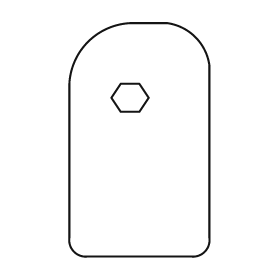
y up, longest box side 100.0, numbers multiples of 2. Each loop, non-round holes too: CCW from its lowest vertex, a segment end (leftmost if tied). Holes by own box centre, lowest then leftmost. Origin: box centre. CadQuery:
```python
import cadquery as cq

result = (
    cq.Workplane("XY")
    .moveTo(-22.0, -50.0)
    .lineTo(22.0, -50.0)
    .threePointArc((28.0, -48.0), (30.0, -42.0))
    .lineTo(30.0, 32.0)
    .threePointArc((24.0, 44.0), (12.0, 50.0))
    .lineTo(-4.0, 50.0)
    .threePointArc((-22.0, 42.0), (-30.0, 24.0))
    .lineTo(-30.0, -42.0)
    .threePointArc((-28.0, -48.0), (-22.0, -50.0))
    .close()
    .moveTo(-8.0, 12.0)
    .lineTo(0.0, 12.0)
    .lineTo(4.0, 18.0)
    .lineTo(0.0, 24.0)
    .lineTo(-8.0, 24.0)
    .lineTo(-12.0, 18.0)
    .close()
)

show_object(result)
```